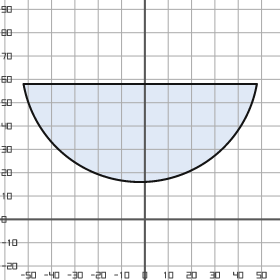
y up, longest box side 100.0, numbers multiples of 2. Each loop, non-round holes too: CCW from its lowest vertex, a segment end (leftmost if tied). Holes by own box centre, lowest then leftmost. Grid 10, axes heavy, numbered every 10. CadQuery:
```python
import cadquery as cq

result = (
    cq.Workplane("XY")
    .moveTo(-52.0, 58.0)
    .threePointArc((-2.0, 16.0), (48.0, 58.0))
    .close()
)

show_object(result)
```